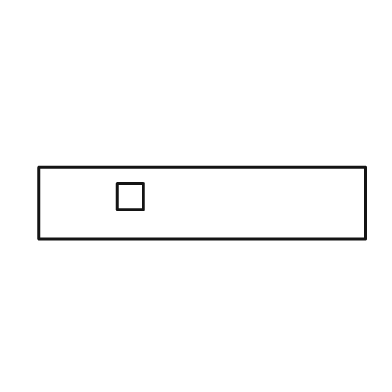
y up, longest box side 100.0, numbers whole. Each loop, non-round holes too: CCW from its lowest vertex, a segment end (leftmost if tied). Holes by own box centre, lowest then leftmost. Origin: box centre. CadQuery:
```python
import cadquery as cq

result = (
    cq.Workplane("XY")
    .moveTo(-50.0, -11.0)
    .lineTo(50.0, -11.0)
    .lineTo(50.0, 11.0)
    .lineTo(-50.0, 11.0)
    .close()
    .moveTo(-26.0, -2.0)
    .lineTo(-18.0, -2.0)
    .lineTo(-18.0, 6.0)
    .lineTo(-26.0, 6.0)
    .close()
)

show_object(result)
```